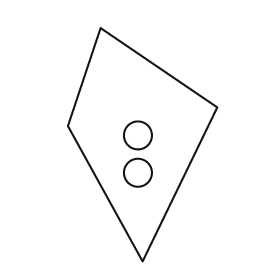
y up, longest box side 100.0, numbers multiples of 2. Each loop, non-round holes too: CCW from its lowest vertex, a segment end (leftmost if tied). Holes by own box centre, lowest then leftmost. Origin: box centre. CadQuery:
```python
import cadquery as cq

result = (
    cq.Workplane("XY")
    .moveTo(0.0, -50.0)
    .lineTo(32.0, 16.0)
    .lineTo(-18.0, 50.0)
    .lineTo(-32.0, 8.0)
    .close()
    .moveTo(-2.0, -12.0)
    .circle(6.0)
    .moveTo(-2.0, 4.0)
    .circle(6.0)
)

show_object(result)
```